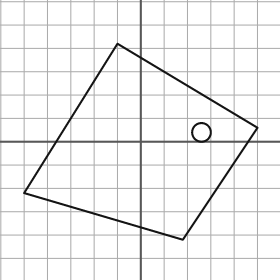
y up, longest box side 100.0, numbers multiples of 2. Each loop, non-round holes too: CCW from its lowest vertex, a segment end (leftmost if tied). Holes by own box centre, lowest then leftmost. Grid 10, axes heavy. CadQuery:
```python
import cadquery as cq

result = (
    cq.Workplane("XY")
    .moveTo(18.0, -42.0)
    .lineTo(50.0, 6.0)
    .lineTo(-10.0, 42.0)
    .lineTo(-50.0, -22.0)
    .close()
    .moveTo(26.0, 4.0)
    .circle(4.0)
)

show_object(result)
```